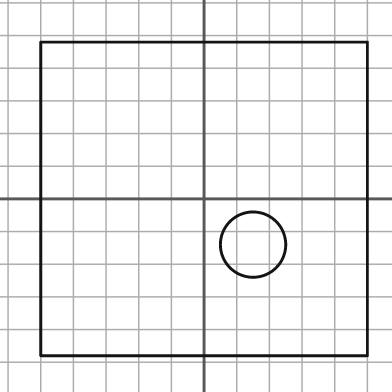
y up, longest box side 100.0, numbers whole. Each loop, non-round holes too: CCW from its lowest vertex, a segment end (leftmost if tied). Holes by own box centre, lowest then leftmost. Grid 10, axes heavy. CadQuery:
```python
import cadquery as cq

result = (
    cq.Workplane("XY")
    .moveTo(-50.0, -48.0)
    .lineTo(50.0, -48.0)
    .lineTo(50.0, 48.0)
    .lineTo(-50.0, 48.0)
    .close()
    .moveTo(15.0, -14.0)
    .circle(10.0)
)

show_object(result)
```